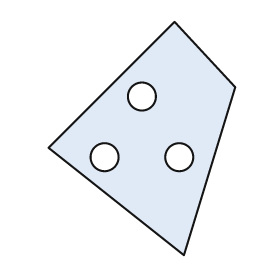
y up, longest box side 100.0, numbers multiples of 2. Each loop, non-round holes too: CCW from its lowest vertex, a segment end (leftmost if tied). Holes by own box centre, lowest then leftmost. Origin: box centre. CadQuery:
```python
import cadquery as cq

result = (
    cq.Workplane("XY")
    .moveTo(18.0, -50.0)
    .lineTo(40.0, 22.0)
    .lineTo(14.0, 50.0)
    .lineTo(-40.0, -4.0)
    .close()
    .moveTo(-16.0, -8.0)
    .circle(6.0)
    .moveTo(16.0, -8.0)
    .circle(6.0)
    .moveTo(0.0, 18.0)
    .circle(6.0)
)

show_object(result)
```